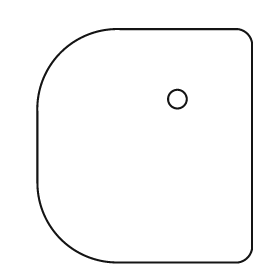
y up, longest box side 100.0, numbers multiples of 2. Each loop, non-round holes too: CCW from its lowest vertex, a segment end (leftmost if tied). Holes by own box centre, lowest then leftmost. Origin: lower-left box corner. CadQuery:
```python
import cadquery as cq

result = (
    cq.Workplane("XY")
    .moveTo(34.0, 0.0)
    .lineTo(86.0, 0.0)
    .threePointArc((90.0, 2.0), (92.0, 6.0))
    .lineTo(92.0, 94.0)
    .threePointArc((90.0, 98.0), (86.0, 100.0))
    .lineTo(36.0, 100.0)
    .threePointArc((10.0, 90.0), (0.0, 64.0))
    .lineTo(0.0, 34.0)
    .threePointArc((10.0, 10.0), (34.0, 0.0))
    .close()
    .moveTo(60.0, 70.0)
    .circle(4.0)
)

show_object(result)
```